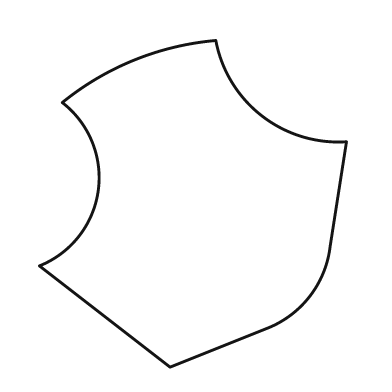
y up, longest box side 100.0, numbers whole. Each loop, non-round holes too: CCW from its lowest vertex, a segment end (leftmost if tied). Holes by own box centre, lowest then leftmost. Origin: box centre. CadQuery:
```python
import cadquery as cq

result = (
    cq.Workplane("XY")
    .moveTo(-7.0, -50.0)
    .lineTo(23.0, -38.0)
    .threePointArc((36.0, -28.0), (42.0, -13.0))
    .lineTo(47.0, 19.0)
    .threePointArc((21.0, 27.0), (7.0, 50.0))
    .threePointArc((-18.0, 44.0), (-40.0, 31.0))
    .threePointArc((-29.0, 4.0), (-47.0, -19.0))
    .close()
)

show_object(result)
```